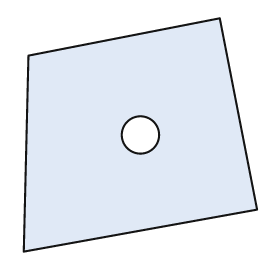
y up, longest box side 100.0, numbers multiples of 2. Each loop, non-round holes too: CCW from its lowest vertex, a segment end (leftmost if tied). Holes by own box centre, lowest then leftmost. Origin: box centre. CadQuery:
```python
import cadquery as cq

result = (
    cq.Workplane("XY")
    .moveTo(-50.0, -50.0)
    .lineTo(50.0, -32.0)
    .lineTo(34.0, 50.0)
    .lineTo(-48.0, 34.0)
    .close()
    .moveTo(0.0, 0.0)
    .circle(8.0)
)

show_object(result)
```